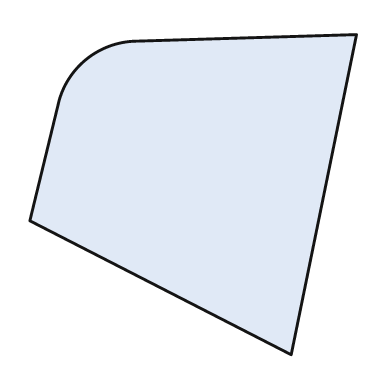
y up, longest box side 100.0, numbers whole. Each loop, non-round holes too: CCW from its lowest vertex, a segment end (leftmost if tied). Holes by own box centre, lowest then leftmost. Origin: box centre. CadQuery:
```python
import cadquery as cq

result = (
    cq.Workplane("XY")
    .moveTo(30.0, -49.0)
    .lineTo(50.0, 49.0)
    .lineTo(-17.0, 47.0)
    .threePointArc((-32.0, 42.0), (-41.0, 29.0))
    .lineTo(-50.0, -8.0)
    .close()
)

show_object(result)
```